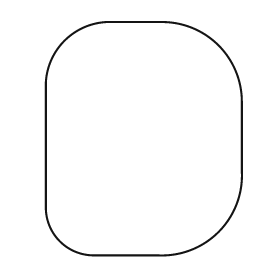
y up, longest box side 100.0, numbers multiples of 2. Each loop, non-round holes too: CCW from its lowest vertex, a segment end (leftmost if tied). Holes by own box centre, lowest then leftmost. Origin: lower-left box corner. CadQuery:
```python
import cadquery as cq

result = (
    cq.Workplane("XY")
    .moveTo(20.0, 0.0)
    .lineTo(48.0, 0.0)
    .threePointArc((74.0, 10.0), (84.0, 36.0))
    .lineTo(84.0, 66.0)
    .threePointArc((74.0, 90.0), (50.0, 100.0))
    .lineTo(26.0, 100.0)
    .threePointArc((8.0, 92.0), (0.0, 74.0))
    .lineTo(0.0, 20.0)
    .threePointArc((6.0, 6.0), (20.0, 0.0))
    .close()
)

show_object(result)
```